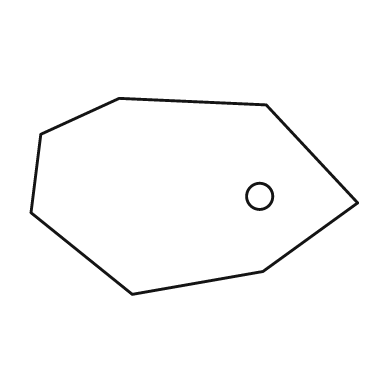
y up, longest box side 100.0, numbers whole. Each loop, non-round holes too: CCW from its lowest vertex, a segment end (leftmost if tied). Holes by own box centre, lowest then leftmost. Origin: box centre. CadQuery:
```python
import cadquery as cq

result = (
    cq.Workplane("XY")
    .moveTo(-19.0, -30.0)
    .lineTo(21.0, -23.0)
    .lineTo(50.0, -2.0)
    .lineTo(22.0, 28.0)
    .lineTo(-23.0, 30.0)
    .lineTo(-47.0, 19.0)
    .lineTo(-50.0, -5.0)
    .close()
    .moveTo(20.0, 0.0)
    .circle(4.0)
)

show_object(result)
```